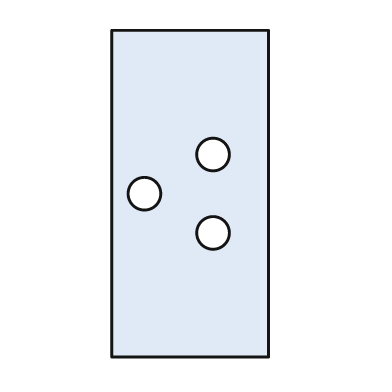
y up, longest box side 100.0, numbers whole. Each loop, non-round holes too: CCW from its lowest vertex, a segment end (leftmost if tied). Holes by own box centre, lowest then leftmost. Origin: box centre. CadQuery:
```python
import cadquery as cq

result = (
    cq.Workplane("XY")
    .moveTo(-24.0, -50.0)
    .lineTo(24.0, -50.0)
    .lineTo(24.0, 50.0)
    .lineTo(-24.0, 50.0)
    .close()
    .moveTo(7.0, -12.0)
    .circle(5.0)
    .moveTo(-14.0, 0.0)
    .circle(5.0)
    .moveTo(7.0, 12.0)
    .circle(5.0)
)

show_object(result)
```